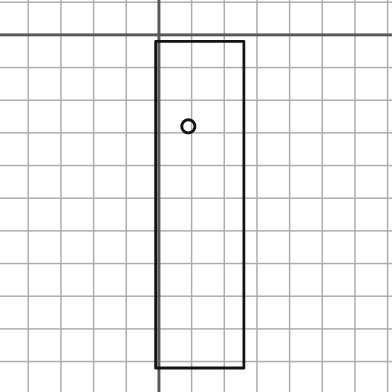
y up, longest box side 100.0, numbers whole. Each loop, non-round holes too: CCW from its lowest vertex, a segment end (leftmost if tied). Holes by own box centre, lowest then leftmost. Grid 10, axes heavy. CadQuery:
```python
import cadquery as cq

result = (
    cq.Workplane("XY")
    .moveTo(-1.0, -102.0)
    .lineTo(26.0, -102.0)
    .lineTo(26.0, -2.0)
    .lineTo(-1.0, -2.0)
    .close()
    .moveTo(9.0, -28.0)
    .circle(2.0)
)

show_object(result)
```